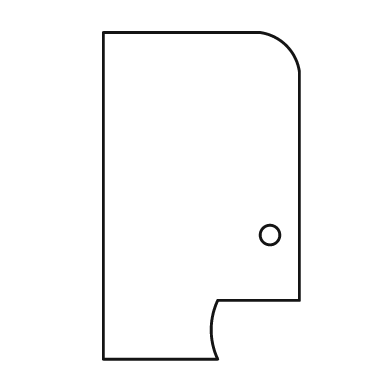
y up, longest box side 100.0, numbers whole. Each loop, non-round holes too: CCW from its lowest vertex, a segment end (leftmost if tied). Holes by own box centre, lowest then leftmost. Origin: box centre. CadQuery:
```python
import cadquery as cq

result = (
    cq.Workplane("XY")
    .moveTo(-30.0, -50.0)
    .lineTo(5.0, -50.0)
    .threePointArc((3.0, -41.0), (5.0, -32.0))
    .lineTo(30.0, -32.0)
    .lineTo(30.0, 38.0)
    .threePointArc((26.0, 46.0), (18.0, 50.0))
    .lineTo(-30.0, 50.0)
    .close()
    .moveTo(21.0, -12.0)
    .circle(3.0)
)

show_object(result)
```